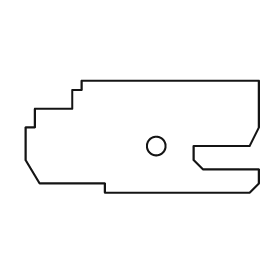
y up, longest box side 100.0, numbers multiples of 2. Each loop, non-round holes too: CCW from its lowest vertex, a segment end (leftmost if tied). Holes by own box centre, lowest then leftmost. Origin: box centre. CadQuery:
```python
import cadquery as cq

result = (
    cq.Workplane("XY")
    .moveTo(-16.0, -24.0)
    .lineTo(46.0, -24.0)
    .lineTo(50.0, -20.0)
    .lineTo(50.0, -14.0)
    .lineTo(26.0, -14.0)
    .lineTo(22.0, -10.0)
    .lineTo(22.0, -4.0)
    .lineTo(46.0, -4.0)
    .lineTo(50.0, 4.0)
    .lineTo(50.0, 24.0)
    .lineTo(-26.0, 24.0)
    .lineTo(-26.0, 20.0)
    .lineTo(-30.0, 20.0)
    .lineTo(-30.0, 12.0)
    .lineTo(-46.0, 12.0)
    .lineTo(-46.0, 4.0)
    .lineTo(-50.0, 4.0)
    .lineTo(-50.0, -10.0)
    .lineTo(-44.0, -20.0)
    .lineTo(-16.0, -20.0)
    .close()
    .moveTo(6.0, -4.0)
    .circle(4.0)
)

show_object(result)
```